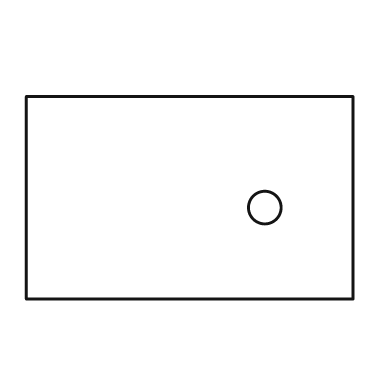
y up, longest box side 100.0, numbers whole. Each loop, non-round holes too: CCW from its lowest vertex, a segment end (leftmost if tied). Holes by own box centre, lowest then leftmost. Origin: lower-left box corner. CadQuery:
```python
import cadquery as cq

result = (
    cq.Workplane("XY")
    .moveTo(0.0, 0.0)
    .lineTo(100.0, 0.0)
    .lineTo(100.0, 62.0)
    .lineTo(0.0, 62.0)
    .close()
    .moveTo(73.0, 28.0)
    .circle(5.0)
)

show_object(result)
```